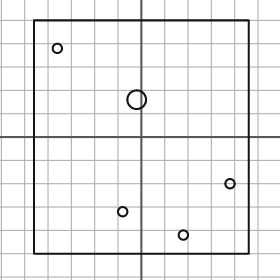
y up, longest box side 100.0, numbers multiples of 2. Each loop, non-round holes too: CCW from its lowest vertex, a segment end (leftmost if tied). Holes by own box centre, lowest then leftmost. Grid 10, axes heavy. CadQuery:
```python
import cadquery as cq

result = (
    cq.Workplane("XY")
    .moveTo(-46.0, -50.0)
    .lineTo(46.0, -50.0)
    .lineTo(46.0, 50.0)
    .lineTo(-46.0, 50.0)
    .close()
    .moveTo(18.0, -42.0)
    .circle(2.0)
    .moveTo(-8.0, -32.0)
    .circle(2.0)
    .moveTo(38.0, -20.0)
    .circle(2.0)
    .moveTo(-2.0, 16.0)
    .circle(4.0)
    .moveTo(-36.0, 38.0)
    .circle(2.0)
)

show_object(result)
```